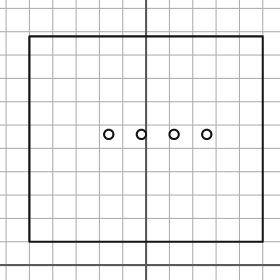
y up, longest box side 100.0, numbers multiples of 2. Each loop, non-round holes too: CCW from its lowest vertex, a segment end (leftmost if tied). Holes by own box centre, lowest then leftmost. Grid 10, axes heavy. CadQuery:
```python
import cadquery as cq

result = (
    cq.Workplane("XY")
    .moveTo(-50.0, 10.0)
    .lineTo(50.0, 10.0)
    .lineTo(50.0, 98.0)
    .lineTo(-50.0, 98.0)
    .close()
    .moveTo(-16.0, 56.0)
    .circle(2.0)
    .moveTo(-2.0, 56.0)
    .circle(2.0)
    .moveTo(12.0, 56.0)
    .circle(2.0)
    .moveTo(26.0, 56.0)
    .circle(2.0)
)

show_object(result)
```